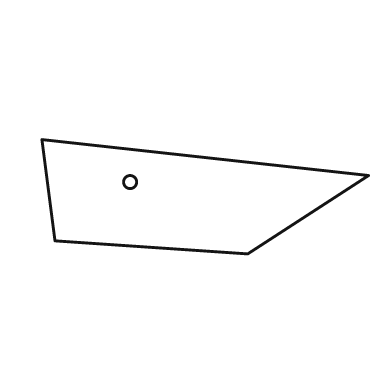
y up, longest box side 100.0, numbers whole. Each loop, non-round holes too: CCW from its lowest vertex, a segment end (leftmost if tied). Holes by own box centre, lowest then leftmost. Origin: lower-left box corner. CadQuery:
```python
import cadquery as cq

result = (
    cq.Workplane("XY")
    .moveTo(63.0, 0.0)
    .lineTo(100.0, 24.0)
    .lineTo(0.0, 35.0)
    .lineTo(4.0, 4.0)
    .close()
    .moveTo(27.0, 22.0)
    .circle(2.0)
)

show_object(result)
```